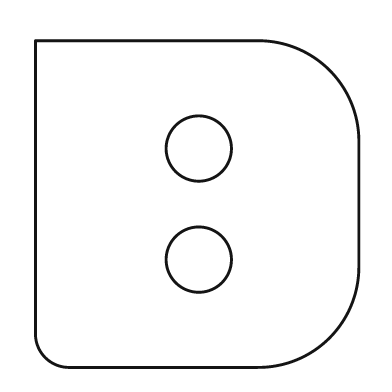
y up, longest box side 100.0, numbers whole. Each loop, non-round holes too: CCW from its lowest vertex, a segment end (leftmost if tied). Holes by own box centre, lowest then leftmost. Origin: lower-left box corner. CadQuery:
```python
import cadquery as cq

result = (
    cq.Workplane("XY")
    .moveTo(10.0, 0.0)
    .lineTo(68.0, 0.0)
    .threePointArc((90.0, 9.0), (99.0, 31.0))
    .lineTo(99.0, 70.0)
    .threePointArc((90.0, 91.0), (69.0, 100.0))
    .lineTo(0.0, 100.0)
    .lineTo(0.0, 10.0)
    .threePointArc((3.0, 3.0), (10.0, 0.0))
    .close()
    .moveTo(50.0, 33.0)
    .circle(10.0)
    .moveTo(50.0, 67.0)
    .circle(10.0)
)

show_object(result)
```